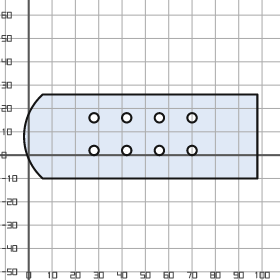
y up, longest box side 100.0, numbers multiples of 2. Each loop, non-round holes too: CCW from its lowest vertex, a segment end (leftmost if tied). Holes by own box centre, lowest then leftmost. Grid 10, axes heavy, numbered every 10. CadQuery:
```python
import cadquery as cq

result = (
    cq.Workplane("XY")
    .moveTo(6.0, -10.0)
    .lineTo(98.0, -10.0)
    .lineTo(98.0, 26.0)
    .lineTo(6.0, 26.0)
    .threePointArc((-2.0, 8.0), (6.0, -10.0))
    .close()
    .moveTo(28.0, 2.0)
    .circle(2.0)
    .moveTo(42.0, 2.0)
    .circle(2.0)
    .moveTo(56.0, 2.0)
    .circle(2.0)
    .moveTo(70.0, 2.0)
    .circle(2.0)
    .moveTo(28.0, 16.0)
    .circle(2.0)
    .moveTo(42.0, 16.0)
    .circle(2.0)
    .moveTo(56.0, 16.0)
    .circle(2.0)
    .moveTo(70.0, 16.0)
    .circle(2.0)
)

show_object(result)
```